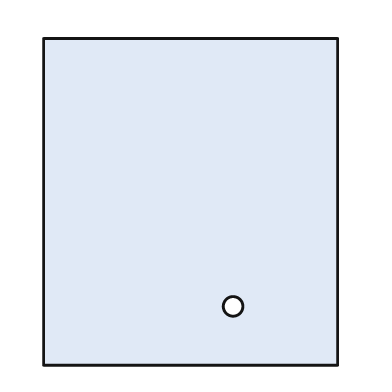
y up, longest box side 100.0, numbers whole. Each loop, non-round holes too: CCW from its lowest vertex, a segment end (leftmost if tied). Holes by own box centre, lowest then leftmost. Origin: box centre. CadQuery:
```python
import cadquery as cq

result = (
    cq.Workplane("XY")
    .moveTo(-45.0, -50.0)
    .lineTo(45.0, -50.0)
    .lineTo(45.0, 50.0)
    .lineTo(-45.0, 50.0)
    .close()
    .moveTo(13.0, -32.0)
    .circle(3.0)
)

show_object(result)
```